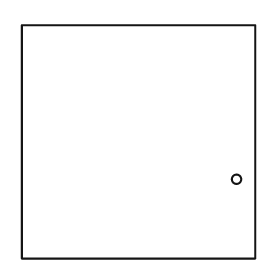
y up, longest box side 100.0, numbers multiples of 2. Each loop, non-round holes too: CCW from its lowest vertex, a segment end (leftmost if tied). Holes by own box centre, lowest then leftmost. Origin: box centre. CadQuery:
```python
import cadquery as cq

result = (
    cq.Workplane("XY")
    .moveTo(-50.0, -50.0)
    .lineTo(50.0, -50.0)
    .lineTo(50.0, 50.0)
    .lineTo(-50.0, 50.0)
    .close()
    .moveTo(42.0, -16.0)
    .circle(2.0)
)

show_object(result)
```